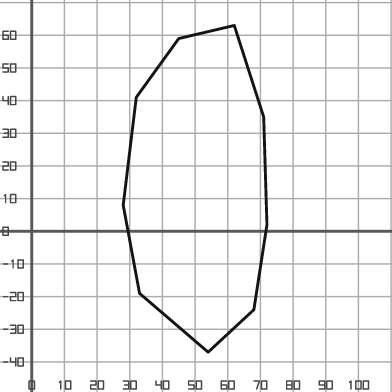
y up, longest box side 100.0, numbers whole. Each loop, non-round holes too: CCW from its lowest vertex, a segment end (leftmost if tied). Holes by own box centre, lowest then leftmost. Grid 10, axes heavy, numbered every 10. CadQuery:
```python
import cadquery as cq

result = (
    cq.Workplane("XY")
    .moveTo(54.0, -37.0)
    .lineTo(68.0, -24.0)
    .lineTo(72.0, 2.0)
    .lineTo(71.0, 35.0)
    .lineTo(62.0, 63.0)
    .lineTo(45.0, 59.0)
    .lineTo(32.0, 41.0)
    .lineTo(28.0, 8.0)
    .lineTo(33.0, -19.0)
    .close()
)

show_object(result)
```